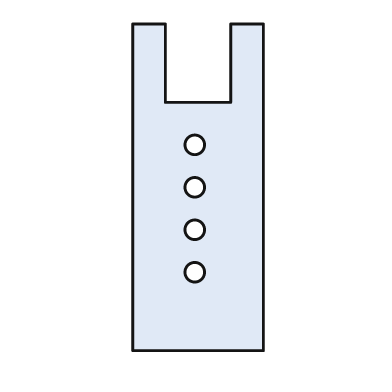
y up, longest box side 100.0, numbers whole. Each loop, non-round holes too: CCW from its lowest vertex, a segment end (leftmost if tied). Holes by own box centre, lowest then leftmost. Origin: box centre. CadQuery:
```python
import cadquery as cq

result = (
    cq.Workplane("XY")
    .moveTo(-20.0, -50.0)
    .lineTo(20.0, -50.0)
    .lineTo(20.0, 50.0)
    .lineTo(10.0, 50.0)
    .lineTo(10.0, 26.0)
    .lineTo(-10.0, 26.0)
    .lineTo(-10.0, 50.0)
    .lineTo(-20.0, 50.0)
    .close()
    .moveTo(-1.0, -26.0)
    .circle(3.0)
    .moveTo(-1.0, -13.0)
    .circle(3.0)
    .moveTo(-1.0, 0.0)
    .circle(3.0)
    .moveTo(-1.0, 13.0)
    .circle(3.0)
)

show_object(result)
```